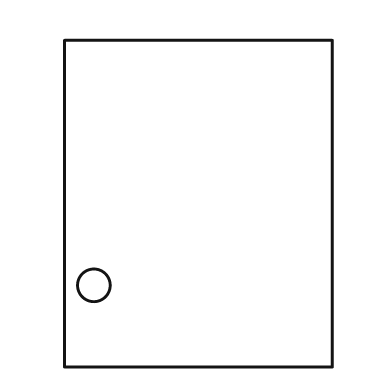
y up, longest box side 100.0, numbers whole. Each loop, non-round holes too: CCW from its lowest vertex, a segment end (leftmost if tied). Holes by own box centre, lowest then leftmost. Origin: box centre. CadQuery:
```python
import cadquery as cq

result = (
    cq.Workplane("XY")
    .moveTo(-41.0, -50.0)
    .lineTo(41.0, -50.0)
    .lineTo(41.0, 50.0)
    .lineTo(-41.0, 50.0)
    .close()
    .moveTo(-32.0, -25.0)
    .circle(5.0)
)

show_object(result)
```